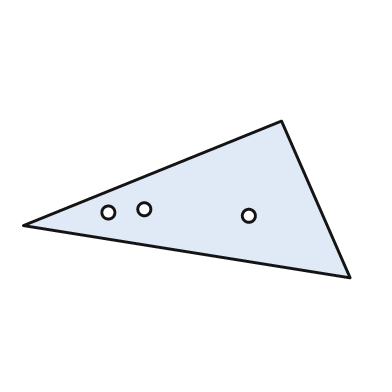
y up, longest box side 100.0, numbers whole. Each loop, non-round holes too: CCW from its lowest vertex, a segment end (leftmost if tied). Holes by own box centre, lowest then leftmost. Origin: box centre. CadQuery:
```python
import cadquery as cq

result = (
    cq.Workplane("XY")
    .moveTo(50.0, -24.0)
    .lineTo(29.0, 24.0)
    .lineTo(-50.0, -8.0)
    .close()
    .moveTo(19.0, -5.0)
    .circle(2.0)
    .moveTo(-24.0, -4.0)
    .circle(2.0)
    .moveTo(-13.0, -3.0)
    .circle(2.0)
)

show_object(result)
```